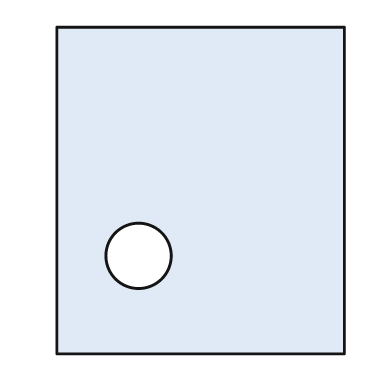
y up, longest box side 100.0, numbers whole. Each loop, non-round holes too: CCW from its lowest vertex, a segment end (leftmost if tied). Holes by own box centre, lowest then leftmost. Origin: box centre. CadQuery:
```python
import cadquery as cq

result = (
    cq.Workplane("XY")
    .moveTo(-44.0, -50.0)
    .lineTo(44.0, -50.0)
    .lineTo(44.0, 50.0)
    .lineTo(-44.0, 50.0)
    .close()
    .moveTo(-19.0, -20.0)
    .circle(10.0)
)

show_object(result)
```